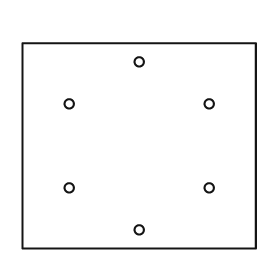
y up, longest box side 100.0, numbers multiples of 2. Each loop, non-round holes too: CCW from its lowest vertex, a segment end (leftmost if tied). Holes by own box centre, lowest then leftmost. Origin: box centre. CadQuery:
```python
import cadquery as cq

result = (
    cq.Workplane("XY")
    .moveTo(-50.0, -44.0)
    .lineTo(50.0, -44.0)
    .lineTo(50.0, 44.0)
    .lineTo(-50.0, 44.0)
    .close()
    .moveTo(0.0, -36.0)
    .circle(2.0)
    .moveTo(-30.0, -18.0)
    .circle(2.0)
    .moveTo(30.0, -18.0)
    .circle(2.0)
    .moveTo(-30.0, 18.0)
    .circle(2.0)
    .moveTo(30.0, 18.0)
    .circle(2.0)
    .moveTo(0.0, 36.0)
    .circle(2.0)
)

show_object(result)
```